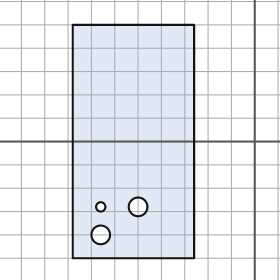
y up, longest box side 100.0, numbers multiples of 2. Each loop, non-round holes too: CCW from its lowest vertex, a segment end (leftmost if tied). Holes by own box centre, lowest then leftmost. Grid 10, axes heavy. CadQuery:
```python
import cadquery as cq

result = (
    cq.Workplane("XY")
    .moveTo(-78.0, -50.0)
    .lineTo(-26.0, -50.0)
    .lineTo(-26.0, 50.0)
    .lineTo(-78.0, 50.0)
    .close()
    .moveTo(-66.0, -40.0)
    .circle(4.0)
    .moveTo(-66.0, -28.0)
    .circle(2.0)
    .moveTo(-50.0, -28.0)
    .circle(4.0)
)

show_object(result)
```